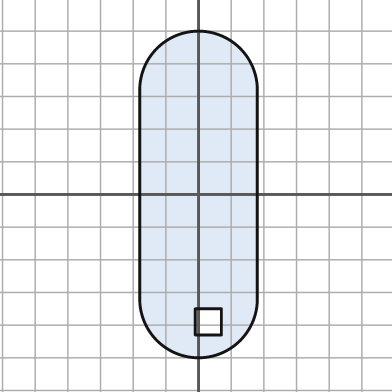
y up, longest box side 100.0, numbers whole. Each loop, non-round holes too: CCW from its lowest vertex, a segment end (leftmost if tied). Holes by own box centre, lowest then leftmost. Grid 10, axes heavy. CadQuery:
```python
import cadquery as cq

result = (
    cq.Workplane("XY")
    .moveTo(-18.0, -32.0)
    .threePointArc((0.0, -50.0), (18.0, -32.0))
    .lineTo(18.0, 32.0)
    .threePointArc((0.0, 50.0), (-18.0, 32.0))
    .close()
    .moveTo(-1.0, -43.0)
    .lineTo(7.0, -43.0)
    .lineTo(7.0, -35.0)
    .lineTo(-1.0, -35.0)
    .close()
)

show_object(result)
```